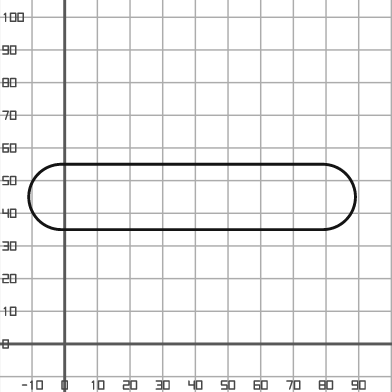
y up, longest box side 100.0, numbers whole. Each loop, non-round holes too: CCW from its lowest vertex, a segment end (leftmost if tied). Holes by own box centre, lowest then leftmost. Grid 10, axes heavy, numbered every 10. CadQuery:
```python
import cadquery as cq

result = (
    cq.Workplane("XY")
    .moveTo(-1.0, 35.0)
    .lineTo(79.0, 35.0)
    .threePointArc((89.0, 45.0), (79.0, 55.0))
    .lineTo(-1.0, 55.0)
    .threePointArc((-11.0, 45.0), (-1.0, 35.0))
    .close()
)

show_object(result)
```